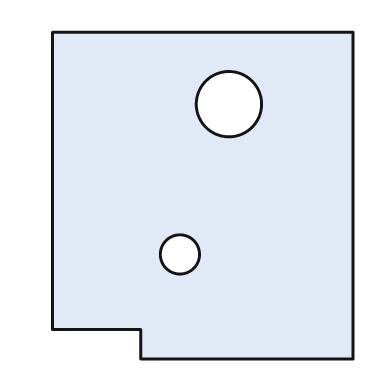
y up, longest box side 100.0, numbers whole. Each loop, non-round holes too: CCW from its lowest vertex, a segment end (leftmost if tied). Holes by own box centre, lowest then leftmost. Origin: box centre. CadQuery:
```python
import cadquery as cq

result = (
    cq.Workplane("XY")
    .moveTo(-19.0, -50.0)
    .lineTo(46.0, -50.0)
    .lineTo(46.0, 50.0)
    .lineTo(-46.0, 50.0)
    .lineTo(-46.0, -41.0)
    .lineTo(-19.0, -41.0)
    .close()
    .moveTo(-7.0, -18.0)
    .circle(6.0)
    .moveTo(8.0, 28.0)
    .circle(10.0)
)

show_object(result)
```